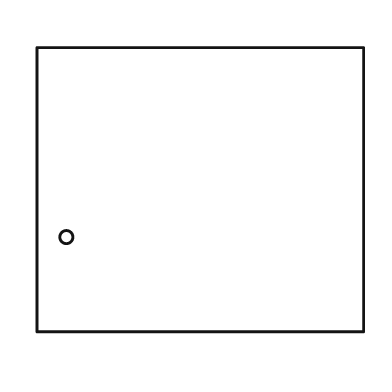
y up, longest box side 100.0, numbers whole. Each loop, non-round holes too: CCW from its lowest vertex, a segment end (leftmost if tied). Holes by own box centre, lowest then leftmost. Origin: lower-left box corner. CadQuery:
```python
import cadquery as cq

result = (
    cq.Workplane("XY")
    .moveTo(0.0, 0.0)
    .lineTo(100.0, 0.0)
    .lineTo(100.0, 87.0)
    .lineTo(0.0, 87.0)
    .close()
    .moveTo(9.0, 29.0)
    .circle(2.0)
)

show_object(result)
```